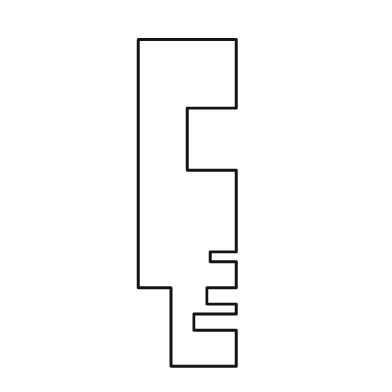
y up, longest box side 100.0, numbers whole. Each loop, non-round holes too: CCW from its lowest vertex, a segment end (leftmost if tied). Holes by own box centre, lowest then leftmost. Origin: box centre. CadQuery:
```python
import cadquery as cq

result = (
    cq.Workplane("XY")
    .moveTo(-5.0, -50.0)
    .lineTo(15.0, -50.0)
    .lineTo(15.0, -39.0)
    .lineTo(2.0, -39.0)
    .lineTo(2.0, -34.0)
    .lineTo(15.0, -34.0)
    .lineTo(15.0, -31.0)
    .lineTo(6.0, -31.0)
    .lineTo(6.0, -26.0)
    .lineTo(15.0, -26.0)
    .lineTo(15.0, -18.0)
    .lineTo(7.0, -18.0)
    .lineTo(7.0, -15.0)
    .lineTo(15.0, -15.0)
    .lineTo(15.0, 10.0)
    .lineTo(0.0, 10.0)
    .lineTo(0.0, 29.0)
    .lineTo(15.0, 29.0)
    .lineTo(15.0, 50.0)
    .lineTo(-15.0, 50.0)
    .lineTo(-15.0, -26.0)
    .lineTo(-5.0, -26.0)
    .close()
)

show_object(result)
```